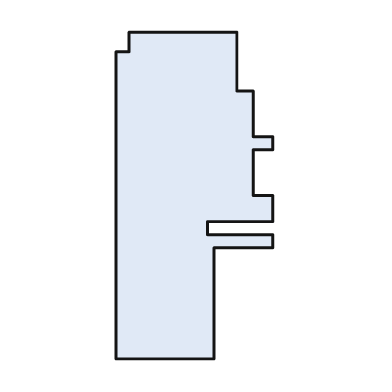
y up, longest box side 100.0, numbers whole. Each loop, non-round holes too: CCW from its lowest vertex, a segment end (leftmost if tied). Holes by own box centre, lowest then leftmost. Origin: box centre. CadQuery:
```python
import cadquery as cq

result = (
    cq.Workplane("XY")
    .moveTo(-24.0, -50.0)
    .lineTo(6.0, -50.0)
    .lineTo(6.0, -16.0)
    .lineTo(24.0, -16.0)
    .lineTo(24.0, -12.0)
    .lineTo(4.0, -12.0)
    .lineTo(4.0, -8.0)
    .lineTo(24.0, -8.0)
    .lineTo(24.0, 0.0)
    .lineTo(18.0, 0.0)
    .lineTo(18.0, 14.0)
    .lineTo(24.0, 14.0)
    .lineTo(24.0, 18.0)
    .lineTo(18.0, 18.0)
    .lineTo(18.0, 32.0)
    .lineTo(13.0, 32.0)
    .lineTo(13.0, 50.0)
    .lineTo(-20.0, 50.0)
    .lineTo(-20.0, 44.0)
    .lineTo(-24.0, 44.0)
    .close()
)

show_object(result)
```